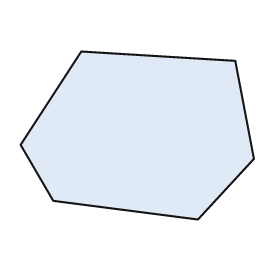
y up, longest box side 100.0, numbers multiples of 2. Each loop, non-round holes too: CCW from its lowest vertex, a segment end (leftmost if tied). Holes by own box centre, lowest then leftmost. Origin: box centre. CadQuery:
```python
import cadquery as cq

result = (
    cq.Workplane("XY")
    .moveTo(26.0, -36.0)
    .lineTo(50.0, -10.0)
    .lineTo(42.0, 32.0)
    .lineTo(-24.0, 36.0)
    .lineTo(-50.0, -4.0)
    .lineTo(-36.0, -28.0)
    .close()
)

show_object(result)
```